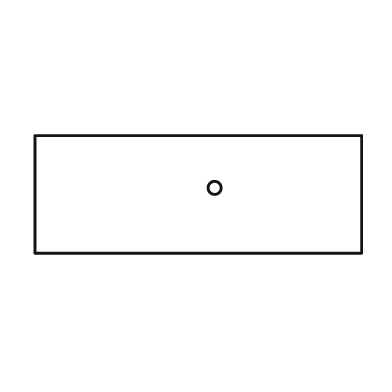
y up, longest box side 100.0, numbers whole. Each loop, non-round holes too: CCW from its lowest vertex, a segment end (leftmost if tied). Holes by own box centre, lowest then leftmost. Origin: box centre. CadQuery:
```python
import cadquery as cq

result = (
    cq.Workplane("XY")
    .moveTo(-50.0, -18.0)
    .lineTo(50.0, -18.0)
    .lineTo(50.0, 18.0)
    .lineTo(-50.0, 18.0)
    .close()
    .moveTo(5.0, 2.0)
    .circle(2.0)
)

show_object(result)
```